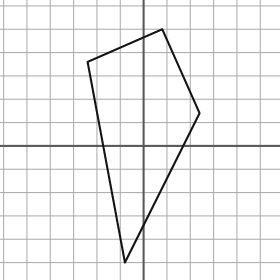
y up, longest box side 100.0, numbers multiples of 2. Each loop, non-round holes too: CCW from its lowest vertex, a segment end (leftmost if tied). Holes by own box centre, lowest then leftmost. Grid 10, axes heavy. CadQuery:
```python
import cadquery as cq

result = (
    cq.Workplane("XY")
    .moveTo(-8.0, -50.0)
    .lineTo(24.0, 14.0)
    .lineTo(8.0, 50.0)
    .lineTo(-24.0, 36.0)
    .close()
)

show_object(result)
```